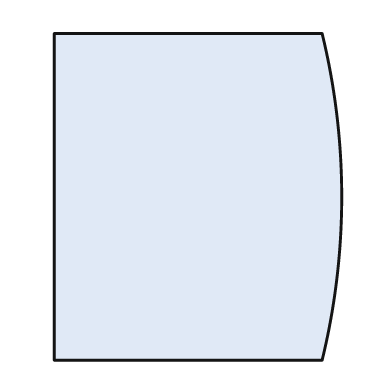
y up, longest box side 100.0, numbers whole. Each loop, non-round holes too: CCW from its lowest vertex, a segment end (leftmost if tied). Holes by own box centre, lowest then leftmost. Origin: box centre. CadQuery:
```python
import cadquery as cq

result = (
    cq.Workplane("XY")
    .moveTo(-44.0, -50.0)
    .lineTo(38.0, -50.0)
    .threePointArc((44.0, 0.0), (38.0, 50.0))
    .lineTo(-44.0, 50.0)
    .close()
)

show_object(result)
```